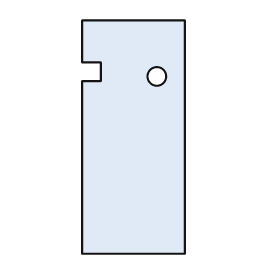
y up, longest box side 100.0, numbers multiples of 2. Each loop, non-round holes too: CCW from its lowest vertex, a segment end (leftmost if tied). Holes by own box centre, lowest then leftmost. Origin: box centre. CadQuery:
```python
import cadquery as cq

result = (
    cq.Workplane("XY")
    .moveTo(-22.0, -50.0)
    .lineTo(22.0, -50.0)
    .lineTo(22.0, 50.0)
    .lineTo(-22.0, 50.0)
    .lineTo(-22.0, 32.0)
    .lineTo(-14.0, 32.0)
    .lineTo(-14.0, 24.0)
    .lineTo(-22.0, 24.0)
    .close()
    .moveTo(10.0, 26.0)
    .circle(4.0)
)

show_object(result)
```